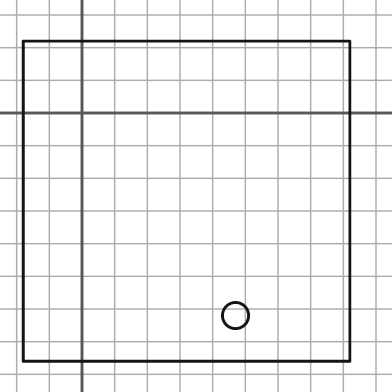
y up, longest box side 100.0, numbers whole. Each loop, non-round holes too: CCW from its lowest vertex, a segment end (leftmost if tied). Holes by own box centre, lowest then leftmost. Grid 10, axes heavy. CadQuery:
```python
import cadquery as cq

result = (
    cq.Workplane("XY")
    .moveTo(-18.0, -76.0)
    .lineTo(82.0, -76.0)
    .lineTo(82.0, 22.0)
    .lineTo(-18.0, 22.0)
    .close()
    .moveTo(47.0, -62.0)
    .circle(4.0)
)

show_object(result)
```